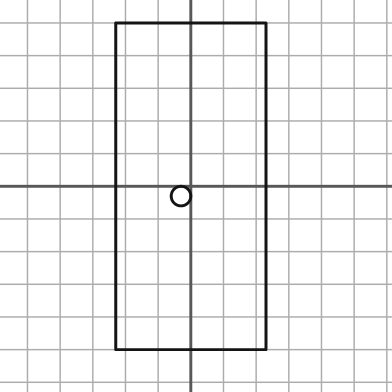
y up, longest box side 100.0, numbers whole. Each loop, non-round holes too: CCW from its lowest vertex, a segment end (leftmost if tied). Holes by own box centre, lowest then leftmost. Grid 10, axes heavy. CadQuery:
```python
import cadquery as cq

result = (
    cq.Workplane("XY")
    .moveTo(-23.0, -50.0)
    .lineTo(23.0, -50.0)
    .lineTo(23.0, 50.0)
    .lineTo(-23.0, 50.0)
    .close()
    .moveTo(-3.0, -3.0)
    .circle(3.0)
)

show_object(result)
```